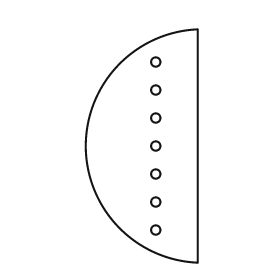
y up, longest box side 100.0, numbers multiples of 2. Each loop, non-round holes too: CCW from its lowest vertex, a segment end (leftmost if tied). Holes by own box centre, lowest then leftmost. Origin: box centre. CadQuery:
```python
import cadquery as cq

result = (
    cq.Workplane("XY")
    .moveTo(24.0, -50.0)
    .lineTo(24.0, 50.0)
    .threePointArc((-24.0, 0.0), (24.0, -50.0))
    .close()
    .moveTo(6.0, -36.0)
    .circle(2.0)
    .moveTo(6.0, -24.0)
    .circle(2.0)
    .moveTo(6.0, -12.0)
    .circle(2.0)
    .moveTo(6.0, 0.0)
    .circle(2.0)
    .moveTo(6.0, 12.0)
    .circle(2.0)
    .moveTo(6.0, 24.0)
    .circle(2.0)
    .moveTo(6.0, 36.0)
    .circle(2.0)
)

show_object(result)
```